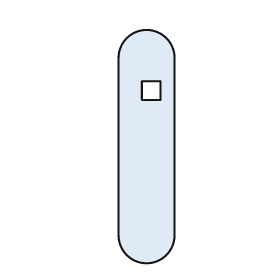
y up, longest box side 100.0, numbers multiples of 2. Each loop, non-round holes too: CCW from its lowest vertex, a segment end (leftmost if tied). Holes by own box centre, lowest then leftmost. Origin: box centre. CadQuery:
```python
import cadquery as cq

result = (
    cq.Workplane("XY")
    .moveTo(-12.0, -38.0)
    .threePointArc((0.0, -50.0), (12.0, -38.0))
    .lineTo(12.0, 38.0)
    .threePointArc((0.0, 50.0), (-12.0, 38.0))
    .close()
    .moveTo(-2.0, 20.0)
    .lineTo(6.0, 20.0)
    .lineTo(6.0, 28.0)
    .lineTo(-2.0, 28.0)
    .close()
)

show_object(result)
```